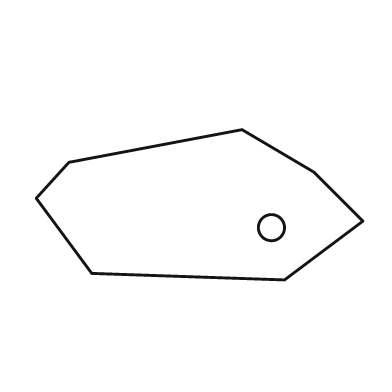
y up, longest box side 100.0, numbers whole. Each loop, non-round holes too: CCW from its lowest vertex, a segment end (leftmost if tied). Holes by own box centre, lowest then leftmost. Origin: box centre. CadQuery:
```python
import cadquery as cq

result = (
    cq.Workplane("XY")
    .moveTo(26.0, -23.0)
    .lineTo(50.0, -5.0)
    .lineTo(35.0, 10.0)
    .lineTo(13.0, 23.0)
    .lineTo(-40.0, 13.0)
    .lineTo(-50.0, 2.0)
    .lineTo(-33.0, -21.0)
    .close()
    .moveTo(22.0, -7.0)
    .circle(4.0)
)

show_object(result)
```